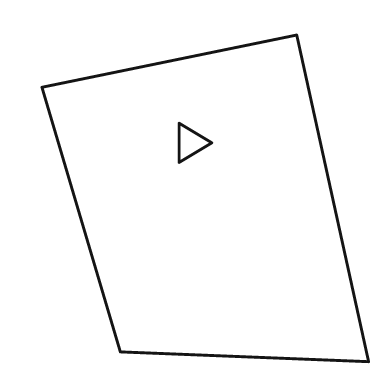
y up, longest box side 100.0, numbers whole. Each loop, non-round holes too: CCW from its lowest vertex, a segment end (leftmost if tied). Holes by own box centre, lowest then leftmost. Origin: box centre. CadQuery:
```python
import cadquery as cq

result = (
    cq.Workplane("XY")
    .moveTo(50.0, -50.0)
    .lineTo(28.0, 50.0)
    .lineTo(-50.0, 34.0)
    .lineTo(-26.0, -47.0)
    .close()
    .moveTo(-8.0, 11.0)
    .lineTo(2.0, 17.0)
    .lineTo(-8.0, 23.0)
    .close()
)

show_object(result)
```